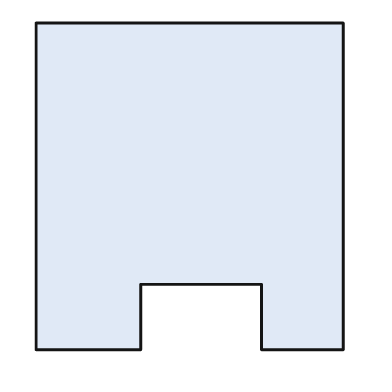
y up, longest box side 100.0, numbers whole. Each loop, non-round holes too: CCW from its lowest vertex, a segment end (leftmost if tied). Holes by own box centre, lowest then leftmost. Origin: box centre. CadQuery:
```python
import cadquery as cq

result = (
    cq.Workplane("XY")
    .moveTo(-47.0, -50.0)
    .lineTo(-15.0, -50.0)
    .lineTo(-15.0, -30.0)
    .lineTo(22.0, -30.0)
    .lineTo(22.0, -50.0)
    .lineTo(47.0, -50.0)
    .lineTo(47.0, 50.0)
    .lineTo(-47.0, 50.0)
    .close()
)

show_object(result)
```